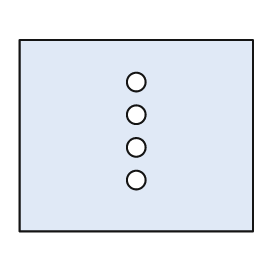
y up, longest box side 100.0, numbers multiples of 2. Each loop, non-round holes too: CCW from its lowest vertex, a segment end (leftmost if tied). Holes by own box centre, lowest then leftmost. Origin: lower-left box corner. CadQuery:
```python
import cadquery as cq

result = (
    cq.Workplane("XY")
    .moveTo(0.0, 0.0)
    .lineTo(100.0, 0.0)
    .lineTo(100.0, 82.0)
    .lineTo(0.0, 82.0)
    .close()
    .moveTo(50.0, 22.0)
    .circle(4.0)
    .moveTo(50.0, 36.0)
    .circle(4.0)
    .moveTo(50.0, 50.0)
    .circle(4.0)
    .moveTo(50.0, 64.0)
    .circle(4.0)
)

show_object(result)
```